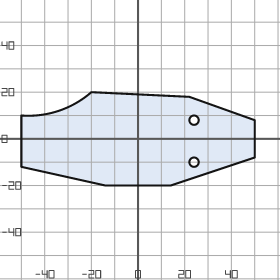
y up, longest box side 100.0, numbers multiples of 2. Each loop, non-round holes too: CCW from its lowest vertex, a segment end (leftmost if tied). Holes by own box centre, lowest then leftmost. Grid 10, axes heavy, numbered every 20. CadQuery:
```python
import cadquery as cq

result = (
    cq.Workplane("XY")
    .moveTo(-14.0, -20.0)
    .lineTo(14.0, -20.0)
    .lineTo(50.0, -8.0)
    .lineTo(50.0, 8.0)
    .lineTo(22.0, 18.0)
    .lineTo(-20.0, 20.0)
    .threePointArc((-34.0, 12.0), (-50.0, 10.0))
    .lineTo(-50.0, -12.0)
    .close()
    .moveTo(24.0, -10.0)
    .circle(2.0)
    .moveTo(24.0, 8.0)
    .circle(2.0)
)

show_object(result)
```